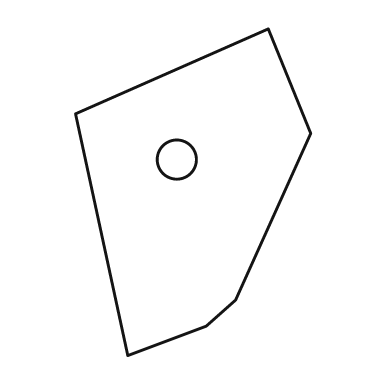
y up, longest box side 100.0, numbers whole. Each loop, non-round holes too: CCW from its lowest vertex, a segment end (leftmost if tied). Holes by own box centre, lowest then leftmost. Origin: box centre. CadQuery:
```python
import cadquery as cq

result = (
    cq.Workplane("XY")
    .moveTo(-20.0, -50.0)
    .lineTo(4.0, -41.0)
    .lineTo(13.0, -33.0)
    .lineTo(36.0, 18.0)
    .lineTo(23.0, 50.0)
    .lineTo(-36.0, 24.0)
    .close()
    .moveTo(-5.0, 10.0)
    .circle(6.0)
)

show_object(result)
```